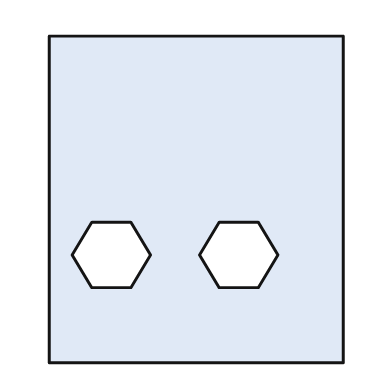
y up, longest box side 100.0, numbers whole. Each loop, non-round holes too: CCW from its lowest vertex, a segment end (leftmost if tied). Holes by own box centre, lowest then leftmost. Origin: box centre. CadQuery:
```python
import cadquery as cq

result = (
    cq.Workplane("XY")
    .moveTo(-45.0, -50.0)
    .lineTo(45.0, -50.0)
    .lineTo(45.0, 50.0)
    .lineTo(-45.0, 50.0)
    .close()
    .moveTo(-32.0, -27.0)
    .lineTo(-20.0, -27.0)
    .lineTo(-14.0, -17.0)
    .lineTo(-20.0, -7.0)
    .lineTo(-32.0, -7.0)
    .lineTo(-38.0, -17.0)
    .close()
    .moveTo(7.0, -27.0)
    .lineTo(19.0, -27.0)
    .lineTo(25.0, -17.0)
    .lineTo(19.0, -7.0)
    .lineTo(7.0, -7.0)
    .lineTo(1.0, -17.0)
    .close()
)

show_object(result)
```